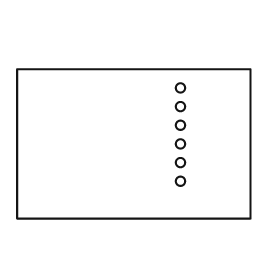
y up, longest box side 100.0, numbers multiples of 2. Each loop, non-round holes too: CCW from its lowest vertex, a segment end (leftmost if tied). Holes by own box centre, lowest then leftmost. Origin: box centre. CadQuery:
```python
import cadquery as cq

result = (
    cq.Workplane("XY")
    .moveTo(-50.0, -32.0)
    .lineTo(50.0, -32.0)
    .lineTo(50.0, 32.0)
    .lineTo(-50.0, 32.0)
    .close()
    .moveTo(20.0, -16.0)
    .circle(2.0)
    .moveTo(20.0, -8.0)
    .circle(2.0)
    .moveTo(20.0, 0.0)
    .circle(2.0)
    .moveTo(20.0, 8.0)
    .circle(2.0)
    .moveTo(20.0, 16.0)
    .circle(2.0)
    .moveTo(20.0, 24.0)
    .circle(2.0)
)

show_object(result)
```